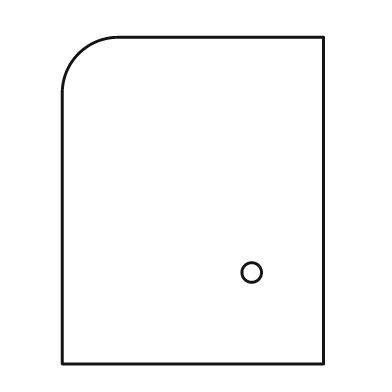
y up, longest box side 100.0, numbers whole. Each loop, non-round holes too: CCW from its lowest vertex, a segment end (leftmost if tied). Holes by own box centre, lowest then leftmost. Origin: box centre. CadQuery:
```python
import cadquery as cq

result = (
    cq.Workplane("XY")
    .moveTo(-40.0, -50.0)
    .lineTo(40.0, -50.0)
    .lineTo(40.0, 50.0)
    .lineTo(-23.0, 50.0)
    .threePointArc((-35.0, 45.0), (-40.0, 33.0))
    .close()
    .moveTo(18.0, -22.0)
    .circle(3.0)
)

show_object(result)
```